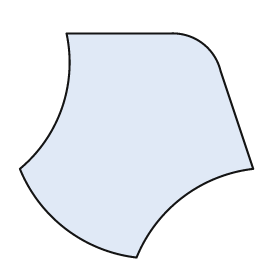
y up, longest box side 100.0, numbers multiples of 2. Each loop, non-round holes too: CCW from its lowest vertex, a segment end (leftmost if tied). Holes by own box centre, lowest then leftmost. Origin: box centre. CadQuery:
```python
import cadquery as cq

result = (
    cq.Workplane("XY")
    .moveTo(0.0, -48.0)
    .threePointArc((20.0, -22.0), (50.0, -10.0))
    .lineTo(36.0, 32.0)
    .threePointArc((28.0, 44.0), (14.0, 48.0))
    .lineTo(-30.0, 48.0)
    .threePointArc((-32.0, 16.0), (-50.0, -10.0))
    .threePointArc((-30.0, -36.0), (0.0, -48.0))
    .close()
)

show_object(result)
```